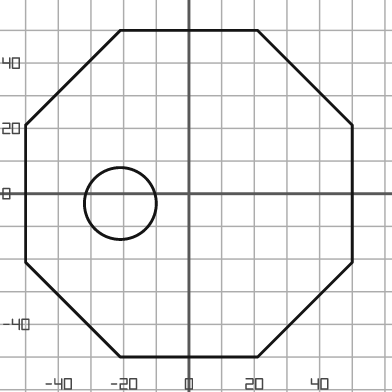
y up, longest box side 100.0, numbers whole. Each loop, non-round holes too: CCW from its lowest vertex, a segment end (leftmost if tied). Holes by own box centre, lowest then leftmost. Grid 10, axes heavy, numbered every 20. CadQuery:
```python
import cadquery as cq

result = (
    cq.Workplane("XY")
    .moveTo(-21.0, -50.0)
    .lineTo(21.0, -50.0)
    .lineTo(50.0, -21.0)
    .lineTo(50.0, 21.0)
    .lineTo(21.0, 50.0)
    .lineTo(-21.0, 50.0)
    .lineTo(-50.0, 21.0)
    .lineTo(-50.0, -21.0)
    .close()
    .moveTo(-21.0, -3.0)
    .circle(11.0)
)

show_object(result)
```